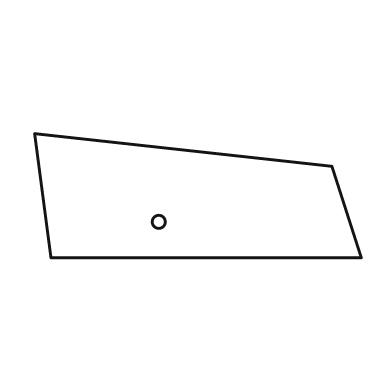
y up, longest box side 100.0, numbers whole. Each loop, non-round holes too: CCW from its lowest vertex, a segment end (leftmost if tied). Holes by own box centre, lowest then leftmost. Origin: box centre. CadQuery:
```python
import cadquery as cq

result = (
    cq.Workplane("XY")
    .moveTo(-45.0, -19.0)
    .lineTo(50.0, -19.0)
    .lineTo(41.0, 9.0)
    .lineTo(-50.0, 19.0)
    .close()
    .moveTo(-12.0, -8.0)
    .circle(2.0)
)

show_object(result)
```